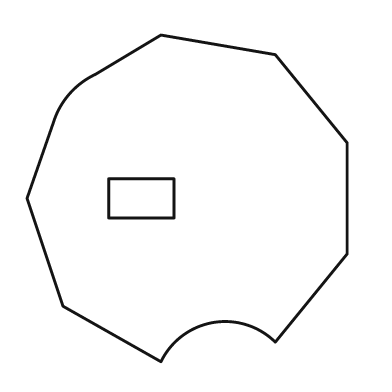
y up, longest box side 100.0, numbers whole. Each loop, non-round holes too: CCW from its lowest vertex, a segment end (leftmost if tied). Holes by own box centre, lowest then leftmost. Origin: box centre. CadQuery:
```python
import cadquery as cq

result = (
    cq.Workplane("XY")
    .moveTo(-8.0, -50.0)
    .threePointArc((8.0, -38.0), (27.0, -44.0))
    .lineTo(49.0, -17.0)
    .lineTo(49.0, 17.0)
    .lineTo(27.0, 44.0)
    .lineTo(-8.0, 50.0)
    .lineTo(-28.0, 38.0)
    .threePointArc((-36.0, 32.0), (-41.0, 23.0))
    .lineTo(-49.0, 0.0)
    .lineTo(-38.0, -33.0)
    .close()
    .moveTo(-24.0, -6.0)
    .lineTo(-4.0, -6.0)
    .lineTo(-4.0, 6.0)
    .lineTo(-24.0, 6.0)
    .close()
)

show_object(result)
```